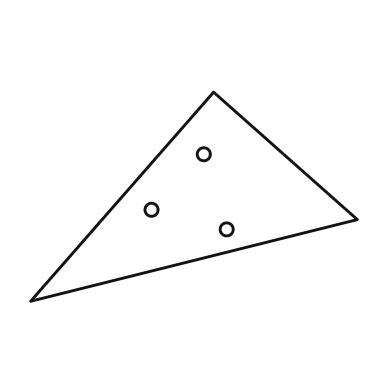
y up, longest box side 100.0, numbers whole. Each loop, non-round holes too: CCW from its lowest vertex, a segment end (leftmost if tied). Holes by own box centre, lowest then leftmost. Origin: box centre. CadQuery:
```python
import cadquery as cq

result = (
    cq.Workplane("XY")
    .moveTo(-50.0, -32.0)
    .lineTo(50.0, -7.0)
    .lineTo(6.0, 32.0)
    .close()
    .moveTo(10.0, -10.0)
    .circle(2.0)
    .moveTo(-13.0, -4.0)
    .circle(2.0)
    .moveTo(3.0, 13.0)
    .circle(2.0)
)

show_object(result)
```